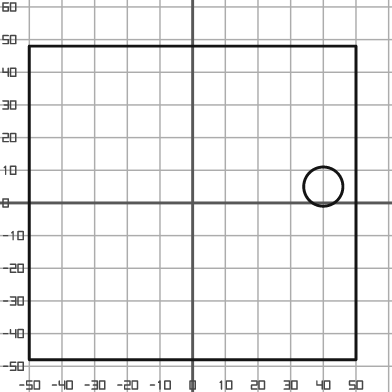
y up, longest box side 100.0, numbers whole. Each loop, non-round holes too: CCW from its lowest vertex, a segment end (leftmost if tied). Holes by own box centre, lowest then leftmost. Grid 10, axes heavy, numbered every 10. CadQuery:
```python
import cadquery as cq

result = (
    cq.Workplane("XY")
    .moveTo(-50.0, -48.0)
    .lineTo(50.0, -48.0)
    .lineTo(50.0, 48.0)
    .lineTo(-50.0, 48.0)
    .close()
    .moveTo(40.0, 5.0)
    .circle(6.0)
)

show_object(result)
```